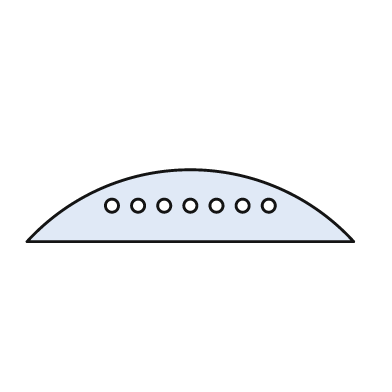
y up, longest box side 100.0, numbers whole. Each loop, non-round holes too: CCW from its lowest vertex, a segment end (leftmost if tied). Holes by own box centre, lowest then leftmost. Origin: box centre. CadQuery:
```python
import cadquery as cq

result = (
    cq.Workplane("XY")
    .moveTo(-50.0, -11.0)
    .lineTo(50.0, -11.0)
    .threePointArc((0.0, 11.0), (-50.0, -11.0))
    .close()
    .moveTo(-24.0, 0.0)
    .circle(2.0)
    .moveTo(-16.0, 0.0)
    .circle(2.0)
    .moveTo(-8.0, 0.0)
    .circle(2.0)
    .moveTo(0.0, 0.0)
    .circle(2.0)
    .moveTo(8.0, 0.0)
    .circle(2.0)
    .moveTo(16.0, 0.0)
    .circle(2.0)
    .moveTo(24.0, 0.0)
    .circle(2.0)
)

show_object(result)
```